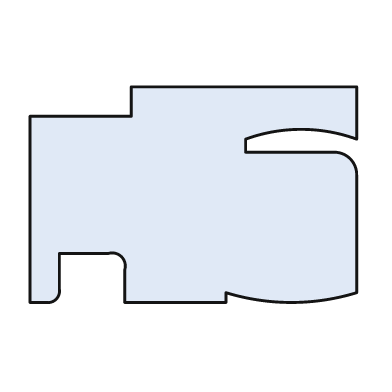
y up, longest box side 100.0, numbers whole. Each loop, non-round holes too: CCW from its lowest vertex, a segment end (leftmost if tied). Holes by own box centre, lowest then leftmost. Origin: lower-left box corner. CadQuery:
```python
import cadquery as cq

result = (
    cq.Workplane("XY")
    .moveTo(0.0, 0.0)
    .lineTo(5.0, 0.0)
    .threePointArc((8.0, 1.0), (9.0, 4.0))
    .lineTo(9.0, 15.0)
    .lineTo(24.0, 15.0)
    .threePointArc((28.0, 14.0), (29.0, 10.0))
    .lineTo(29.0, 0.0)
    .lineTo(60.0, 0.0)
    .lineTo(60.0, 3.0)
    .threePointArc((80.0, 0.0), (100.0, 3.0))
    .lineTo(100.0, 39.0)
    .threePointArc((98.0, 44.0), (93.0, 46.0))
    .lineTo(66.0, 46.0)
    .lineTo(66.0, 50.0)
    .threePointArc((83.0, 53.0), (100.0, 50.0))
    .lineTo(100.0, 66.0)
    .lineTo(31.0, 66.0)
    .lineTo(31.0, 57.0)
    .lineTo(0.0, 57.0)
    .close()
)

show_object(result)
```